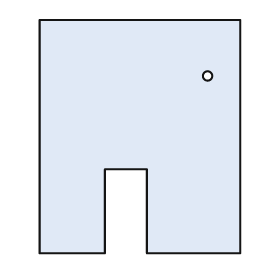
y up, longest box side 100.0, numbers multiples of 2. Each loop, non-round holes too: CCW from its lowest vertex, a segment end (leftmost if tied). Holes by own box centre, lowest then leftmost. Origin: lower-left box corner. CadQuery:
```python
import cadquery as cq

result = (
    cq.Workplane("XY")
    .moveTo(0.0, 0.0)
    .lineTo(28.0, 0.0)
    .lineTo(28.0, 36.0)
    .lineTo(46.0, 36.0)
    .lineTo(46.0, 0.0)
    .lineTo(86.0, 0.0)
    .lineTo(86.0, 100.0)
    .lineTo(0.0, 100.0)
    .close()
    .moveTo(72.0, 76.0)
    .circle(2.0)
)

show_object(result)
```